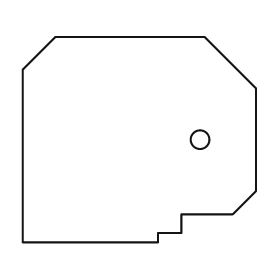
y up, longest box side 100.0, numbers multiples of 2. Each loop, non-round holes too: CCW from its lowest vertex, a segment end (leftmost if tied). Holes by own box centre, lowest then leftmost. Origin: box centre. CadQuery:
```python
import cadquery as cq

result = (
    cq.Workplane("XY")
    .moveTo(-50.0, -44.0)
    .lineTo(8.0, -44.0)
    .lineTo(8.0, -40.0)
    .lineTo(18.0, -40.0)
    .lineTo(18.0, -32.0)
    .lineTo(40.0, -32.0)
    .lineTo(50.0, -22.0)
    .lineTo(50.0, 22.0)
    .lineTo(28.0, 44.0)
    .lineTo(-36.0, 44.0)
    .lineTo(-50.0, 30.0)
    .close()
    .moveTo(26.0, 0.0)
    .circle(4.0)
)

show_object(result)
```